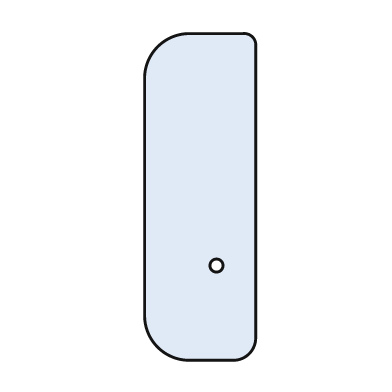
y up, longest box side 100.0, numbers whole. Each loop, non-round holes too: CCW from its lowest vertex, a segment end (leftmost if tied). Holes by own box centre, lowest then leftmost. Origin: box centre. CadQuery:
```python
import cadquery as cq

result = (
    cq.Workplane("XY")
    .moveTo(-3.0, -50.0)
    .lineTo(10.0, -50.0)
    .threePointArc((15.0, -48.0), (17.0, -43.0))
    .lineTo(17.0, 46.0)
    .threePointArc((16.0, 49.0), (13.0, 50.0))
    .lineTo(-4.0, 50.0)
    .threePointArc((-13.0, 46.0), (-17.0, 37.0))
    .lineTo(-17.0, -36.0)
    .threePointArc((-13.0, -46.0), (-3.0, -50.0))
    .close()
    .moveTo(5.0, -21.0)
    .circle(2.0)
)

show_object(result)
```